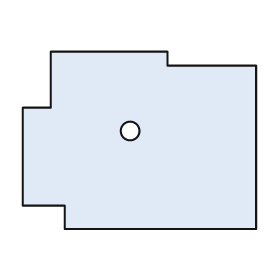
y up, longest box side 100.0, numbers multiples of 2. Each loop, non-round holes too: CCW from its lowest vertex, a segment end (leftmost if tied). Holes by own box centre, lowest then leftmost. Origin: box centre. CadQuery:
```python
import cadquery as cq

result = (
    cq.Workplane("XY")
    .moveTo(-32.0, -38.0)
    .lineTo(50.0, -38.0)
    .lineTo(50.0, 32.0)
    .lineTo(12.0, 32.0)
    .lineTo(12.0, 38.0)
    .lineTo(-38.0, 38.0)
    .lineTo(-38.0, 14.0)
    .lineTo(-50.0, 14.0)
    .lineTo(-50.0, -28.0)
    .lineTo(-32.0, -28.0)
    .close()
    .moveTo(-4.0, 4.0)
    .circle(4.0)
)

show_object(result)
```